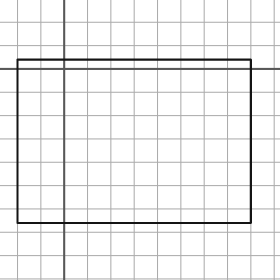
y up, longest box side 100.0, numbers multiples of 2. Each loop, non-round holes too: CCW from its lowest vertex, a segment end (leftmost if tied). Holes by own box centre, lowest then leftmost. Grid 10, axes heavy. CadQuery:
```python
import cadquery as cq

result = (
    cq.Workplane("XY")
    .moveTo(-20.0, -66.0)
    .lineTo(80.0, -66.0)
    .lineTo(80.0, 4.0)
    .lineTo(-20.0, 4.0)
    .close()
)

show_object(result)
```